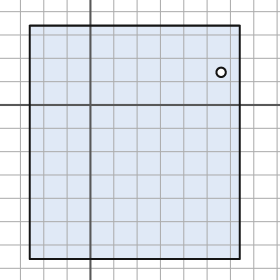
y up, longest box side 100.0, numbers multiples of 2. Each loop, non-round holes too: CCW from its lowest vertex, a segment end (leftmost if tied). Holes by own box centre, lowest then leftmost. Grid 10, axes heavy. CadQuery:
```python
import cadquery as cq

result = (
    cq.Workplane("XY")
    .moveTo(-26.0, -66.0)
    .lineTo(64.0, -66.0)
    .lineTo(64.0, 34.0)
    .lineTo(-26.0, 34.0)
    .close()
    .moveTo(56.0, 14.0)
    .circle(2.0)
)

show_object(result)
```